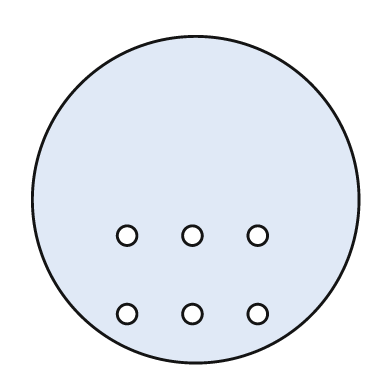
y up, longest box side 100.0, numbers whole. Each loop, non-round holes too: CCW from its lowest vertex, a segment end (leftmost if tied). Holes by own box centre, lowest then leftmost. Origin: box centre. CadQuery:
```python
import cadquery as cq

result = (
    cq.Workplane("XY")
    .moveTo(0.0, 0.0)
    .circle(50.0)
    .moveTo(-21.0, -35.0)
    .circle(3.0)
    .moveTo(-1.0, -35.0)
    .circle(3.0)
    .moveTo(19.0, -35.0)
    .circle(3.0)
    .moveTo(-21.0, -11.0)
    .circle(3.0)
    .moveTo(-1.0, -11.0)
    .circle(3.0)
    .moveTo(19.0, -11.0)
    .circle(3.0)
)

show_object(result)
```